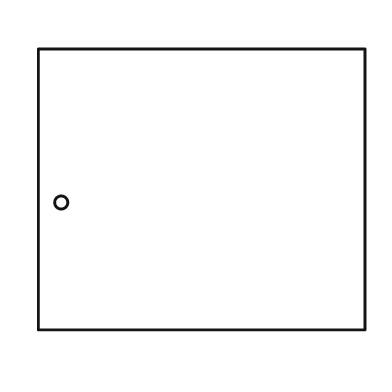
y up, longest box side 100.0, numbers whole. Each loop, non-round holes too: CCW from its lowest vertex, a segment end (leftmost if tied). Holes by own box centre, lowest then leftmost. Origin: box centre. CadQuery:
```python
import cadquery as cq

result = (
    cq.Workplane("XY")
    .moveTo(-50.0, -43.0)
    .lineTo(50.0, -43.0)
    .lineTo(50.0, 43.0)
    .lineTo(-50.0, 43.0)
    .close()
    .moveTo(-43.0, -4.0)
    .circle(2.0)
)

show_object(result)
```